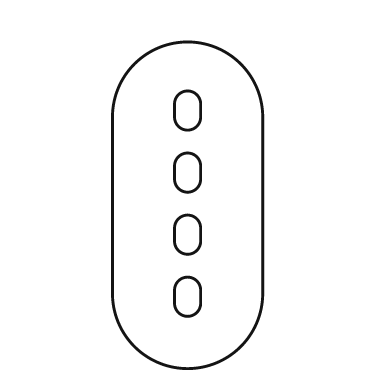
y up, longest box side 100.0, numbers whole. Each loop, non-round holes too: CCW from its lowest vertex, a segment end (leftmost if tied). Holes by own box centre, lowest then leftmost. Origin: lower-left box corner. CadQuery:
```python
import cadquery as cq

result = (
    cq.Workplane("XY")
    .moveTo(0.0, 23.0)
    .threePointArc((23.0, 0.0), (46.0, 23.0))
    .lineTo(46.0, 77.0)
    .threePointArc((23.0, 100.0), (0.0, 77.0))
    .close()
    .moveTo(19.0, 20.0)
    .threePointArc((23.0, 16.0), (27.0, 20.0))
    .lineTo(27.0, 24.0)
    .threePointArc((23.0, 28.0), (19.0, 24.0))
    .close()
    .moveTo(19.0, 39.0)
    .threePointArc((23.0, 35.0), (27.0, 39.0))
    .lineTo(27.0, 43.0)
    .threePointArc((23.0, 47.0), (19.0, 43.0))
    .close()
    .moveTo(19.0, 58.0)
    .threePointArc((23.0, 54.0), (27.0, 58.0))
    .lineTo(27.0, 62.0)
    .threePointArc((23.0, 66.0), (19.0, 62.0))
    .close()
    .moveTo(19.0, 77.0)
    .threePointArc((23.0, 73.0), (27.0, 77.0))
    .lineTo(27.0, 81.0)
    .threePointArc((23.0, 85.0), (19.0, 81.0))
    .close()
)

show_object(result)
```